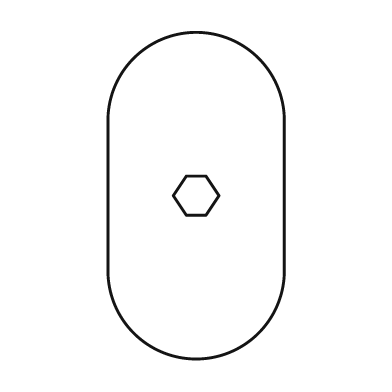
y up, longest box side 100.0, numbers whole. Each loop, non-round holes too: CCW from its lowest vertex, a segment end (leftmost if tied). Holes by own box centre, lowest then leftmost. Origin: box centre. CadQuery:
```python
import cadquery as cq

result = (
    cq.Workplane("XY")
    .moveTo(-27.0, -23.0)
    .threePointArc((0.0, -50.0), (27.0, -23.0))
    .lineTo(27.0, 23.0)
    .threePointArc((0.0, 50.0), (-27.0, 23.0))
    .close()
    .moveTo(-3.0, -6.0)
    .lineTo(3.0, -6.0)
    .lineTo(7.0, 0.0)
    .lineTo(3.0, 6.0)
    .lineTo(-3.0, 6.0)
    .lineTo(-7.0, 0.0)
    .close()
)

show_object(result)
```